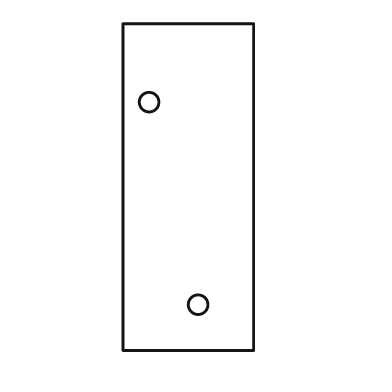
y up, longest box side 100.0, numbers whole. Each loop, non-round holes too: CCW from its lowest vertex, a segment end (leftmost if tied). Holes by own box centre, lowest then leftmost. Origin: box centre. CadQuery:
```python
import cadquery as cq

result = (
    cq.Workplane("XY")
    .moveTo(-20.0, -50.0)
    .lineTo(20.0, -50.0)
    .lineTo(20.0, 50.0)
    .lineTo(-20.0, 50.0)
    .close()
    .moveTo(3.0, -36.0)
    .circle(3.0)
    .moveTo(-12.0, 26.0)
    .circle(3.0)
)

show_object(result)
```